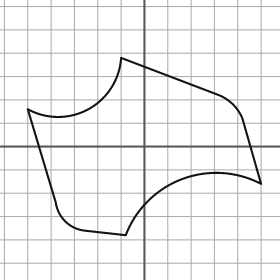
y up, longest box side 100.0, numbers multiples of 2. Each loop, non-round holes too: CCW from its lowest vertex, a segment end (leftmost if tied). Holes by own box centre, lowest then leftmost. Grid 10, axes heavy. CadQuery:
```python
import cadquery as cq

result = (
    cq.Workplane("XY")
    .moveTo(-8.0, -38.0)
    .threePointArc((16.0, -14.0), (50.0, -16.0))
    .lineTo(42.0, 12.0)
    .threePointArc((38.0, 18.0), (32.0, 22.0))
    .lineTo(-10.0, 38.0)
    .threePointArc((-24.0, 16.0), (-50.0, 16.0))
    .lineTo(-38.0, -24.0)
    .threePointArc((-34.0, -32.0), (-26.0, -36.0))
    .close()
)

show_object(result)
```